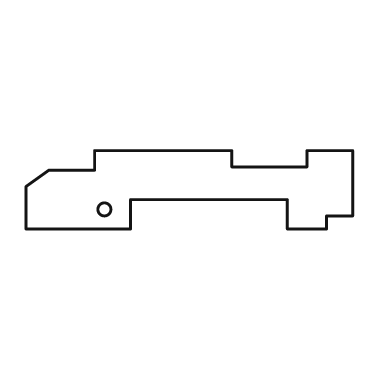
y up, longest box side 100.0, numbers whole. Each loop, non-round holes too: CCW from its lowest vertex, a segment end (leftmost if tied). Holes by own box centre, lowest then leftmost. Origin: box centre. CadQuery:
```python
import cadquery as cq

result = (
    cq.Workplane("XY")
    .moveTo(-50.0, -12.0)
    .lineTo(-18.0, -12.0)
    .lineTo(-18.0, -3.0)
    .lineTo(30.0, -3.0)
    .lineTo(30.0, -12.0)
    .lineTo(42.0, -12.0)
    .lineTo(42.0, -8.0)
    .lineTo(50.0, -8.0)
    .lineTo(50.0, 12.0)
    .lineTo(36.0, 12.0)
    .lineTo(36.0, 7.0)
    .lineTo(13.0, 7.0)
    .lineTo(13.0, 12.0)
    .lineTo(-29.0, 12.0)
    .lineTo(-29.0, 6.0)
    .lineTo(-43.0, 6.0)
    .lineTo(-50.0, 1.0)
    .close()
    .moveTo(-26.0, -6.0)
    .circle(2.0)
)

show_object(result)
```